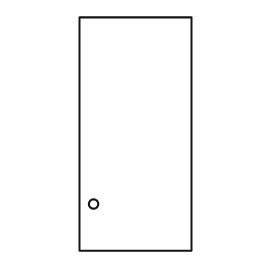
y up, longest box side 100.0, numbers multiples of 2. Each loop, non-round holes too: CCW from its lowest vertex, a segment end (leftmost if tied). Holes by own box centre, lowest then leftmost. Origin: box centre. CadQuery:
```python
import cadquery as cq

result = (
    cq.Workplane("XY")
    .moveTo(-24.0, -50.0)
    .lineTo(24.0, -50.0)
    .lineTo(24.0, 50.0)
    .lineTo(-24.0, 50.0)
    .close()
    .moveTo(-18.0, -30.0)
    .circle(2.0)
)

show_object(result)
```